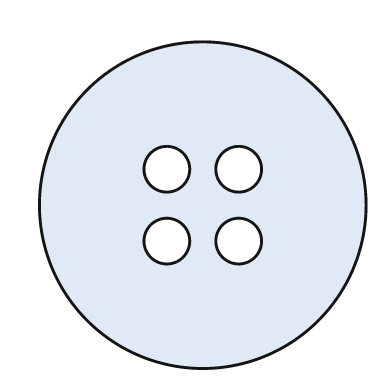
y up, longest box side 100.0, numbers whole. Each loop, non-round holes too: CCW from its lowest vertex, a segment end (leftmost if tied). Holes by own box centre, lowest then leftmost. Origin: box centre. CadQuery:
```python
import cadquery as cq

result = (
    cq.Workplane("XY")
    .moveTo(0.0, 0.0)
    .circle(50.0)
    .moveTo(-11.0, -11.0)
    .circle(7.0)
    .moveTo(11.0, -11.0)
    .circle(7.0)
    .moveTo(-11.0, 11.0)
    .circle(7.0)
    .moveTo(11.0, 11.0)
    .circle(7.0)
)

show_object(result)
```